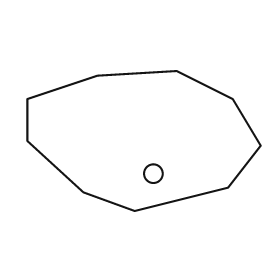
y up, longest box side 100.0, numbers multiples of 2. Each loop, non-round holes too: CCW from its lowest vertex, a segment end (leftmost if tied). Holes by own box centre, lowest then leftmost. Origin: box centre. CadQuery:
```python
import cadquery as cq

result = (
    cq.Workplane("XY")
    .moveTo(-4.0, -30.0)
    .lineTo(36.0, -20.0)
    .lineTo(50.0, -2.0)
    .lineTo(38.0, 18.0)
    .lineTo(14.0, 30.0)
    .lineTo(-20.0, 28.0)
    .lineTo(-50.0, 18.0)
    .lineTo(-50.0, 0.0)
    .lineTo(-26.0, -22.0)
    .close()
    .moveTo(4.0, -14.0)
    .circle(4.0)
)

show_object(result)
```